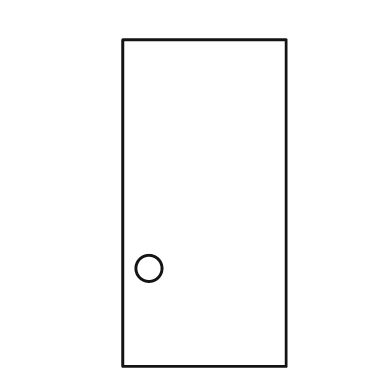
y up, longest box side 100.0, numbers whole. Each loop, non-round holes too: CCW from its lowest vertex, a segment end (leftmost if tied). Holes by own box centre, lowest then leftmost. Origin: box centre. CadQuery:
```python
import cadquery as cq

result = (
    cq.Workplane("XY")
    .moveTo(-25.0, -50.0)
    .lineTo(25.0, -50.0)
    .lineTo(25.0, 50.0)
    .lineTo(-25.0, 50.0)
    .close()
    .moveTo(-17.0, -20.0)
    .circle(4.0)
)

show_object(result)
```